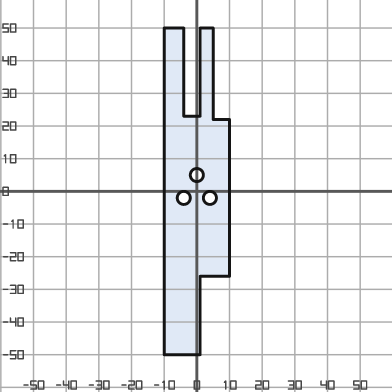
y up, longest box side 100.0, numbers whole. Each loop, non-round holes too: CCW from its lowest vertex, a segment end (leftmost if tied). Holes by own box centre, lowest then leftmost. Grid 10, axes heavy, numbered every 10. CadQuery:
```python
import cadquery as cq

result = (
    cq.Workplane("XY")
    .moveTo(-10.0, -50.0)
    .lineTo(1.0, -50.0)
    .lineTo(1.0, -26.0)
    .lineTo(10.0, -26.0)
    .lineTo(10.0, 22.0)
    .lineTo(5.0, 22.0)
    .lineTo(5.0, 50.0)
    .lineTo(1.0, 50.0)
    .lineTo(1.0, 23.0)
    .lineTo(-4.0, 23.0)
    .lineTo(-4.0, 50.0)
    .lineTo(-10.0, 50.0)
    .close()
    .moveTo(-4.0, -2.0)
    .circle(2.0)
    .moveTo(4.0, -2.0)
    .circle(2.0)
    .moveTo(0.0, 5.0)
    .circle(2.0)
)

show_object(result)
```